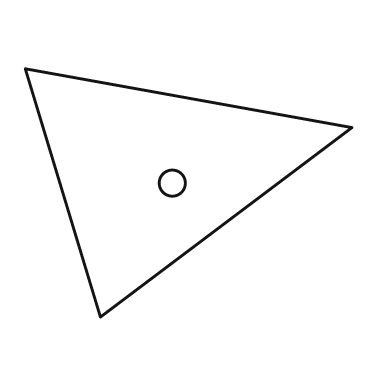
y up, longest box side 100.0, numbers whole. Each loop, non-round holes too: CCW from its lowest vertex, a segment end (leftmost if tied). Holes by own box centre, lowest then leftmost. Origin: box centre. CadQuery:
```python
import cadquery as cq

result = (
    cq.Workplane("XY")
    .moveTo(-27.0, -38.0)
    .lineTo(50.0, 20.0)
    .lineTo(-50.0, 38.0)
    .close()
    .moveTo(-5.0, 3.0)
    .circle(4.0)
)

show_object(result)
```